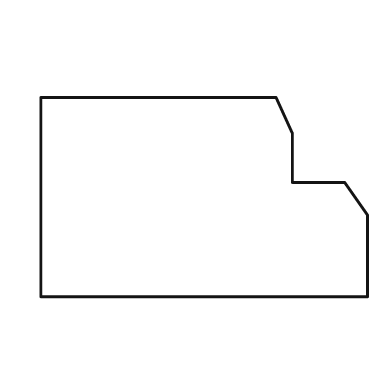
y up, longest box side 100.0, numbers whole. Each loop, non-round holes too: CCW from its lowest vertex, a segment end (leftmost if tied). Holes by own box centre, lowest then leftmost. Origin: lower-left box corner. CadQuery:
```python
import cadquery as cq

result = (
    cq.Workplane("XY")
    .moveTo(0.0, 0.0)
    .lineTo(100.0, 0.0)
    .lineTo(100.0, 25.0)
    .lineTo(93.0, 35.0)
    .lineTo(77.0, 35.0)
    .lineTo(77.0, 50.0)
    .lineTo(72.0, 61.0)
    .lineTo(0.0, 61.0)
    .close()
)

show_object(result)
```